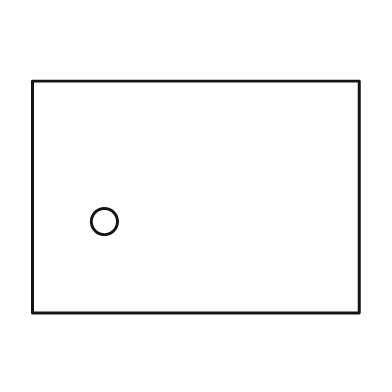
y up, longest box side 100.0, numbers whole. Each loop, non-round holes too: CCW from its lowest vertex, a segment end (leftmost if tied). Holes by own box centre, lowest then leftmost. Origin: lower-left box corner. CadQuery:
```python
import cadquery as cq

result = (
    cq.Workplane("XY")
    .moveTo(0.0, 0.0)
    .lineTo(100.0, 0.0)
    .lineTo(100.0, 71.0)
    .lineTo(0.0, 71.0)
    .close()
    .moveTo(22.0, 28.0)
    .circle(4.0)
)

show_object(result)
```